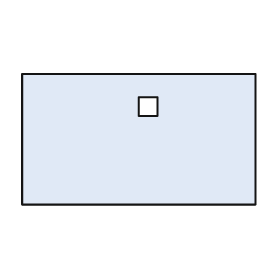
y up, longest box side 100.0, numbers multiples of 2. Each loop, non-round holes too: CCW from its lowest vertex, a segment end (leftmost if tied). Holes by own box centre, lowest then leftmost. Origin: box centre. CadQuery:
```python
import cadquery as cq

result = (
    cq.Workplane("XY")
    .moveTo(-50.0, -28.0)
    .lineTo(50.0, -28.0)
    .lineTo(50.0, 28.0)
    .lineTo(-50.0, 28.0)
    .close()
    .moveTo(0.0, 10.0)
    .lineTo(8.0, 10.0)
    .lineTo(8.0, 18.0)
    .lineTo(0.0, 18.0)
    .close()
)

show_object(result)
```